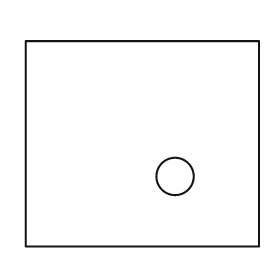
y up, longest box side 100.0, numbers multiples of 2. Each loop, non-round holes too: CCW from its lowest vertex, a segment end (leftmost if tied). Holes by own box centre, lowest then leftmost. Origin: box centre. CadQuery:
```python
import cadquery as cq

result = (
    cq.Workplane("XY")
    .moveTo(-50.0, -44.0)
    .lineTo(50.0, -44.0)
    .lineTo(50.0, 44.0)
    .lineTo(-50.0, 44.0)
    .close()
    .moveTo(14.0, -14.0)
    .circle(8.0)
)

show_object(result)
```